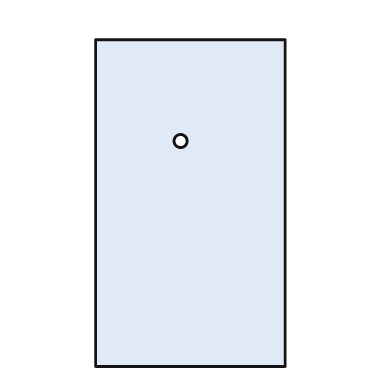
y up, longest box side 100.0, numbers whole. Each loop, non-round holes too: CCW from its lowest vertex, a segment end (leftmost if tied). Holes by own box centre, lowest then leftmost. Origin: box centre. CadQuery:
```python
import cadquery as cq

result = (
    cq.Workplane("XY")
    .moveTo(-29.0, -50.0)
    .lineTo(29.0, -50.0)
    .lineTo(29.0, 50.0)
    .lineTo(-29.0, 50.0)
    .close()
    .moveTo(-3.0, 19.0)
    .circle(2.0)
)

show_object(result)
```